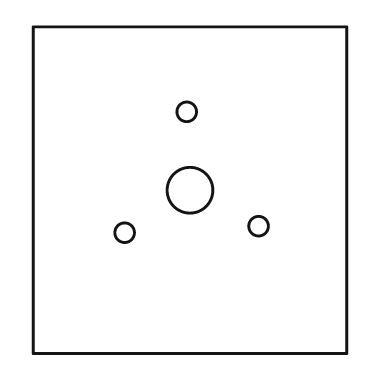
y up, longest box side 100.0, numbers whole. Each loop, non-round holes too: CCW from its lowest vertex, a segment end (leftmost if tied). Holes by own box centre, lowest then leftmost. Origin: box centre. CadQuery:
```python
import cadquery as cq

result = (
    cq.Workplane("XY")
    .moveTo(-48.0, -50.0)
    .lineTo(48.0, -50.0)
    .lineTo(48.0, 50.0)
    .lineTo(-48.0, 50.0)
    .close()
    .moveTo(-20.0, -13.0)
    .circle(3.0)
    .moveTo(21.0, -11.0)
    .circle(3.0)
    .moveTo(0.0, 0.0)
    .circle(7.0)
    .moveTo(-1.0, 24.0)
    .circle(3.0)
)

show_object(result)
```